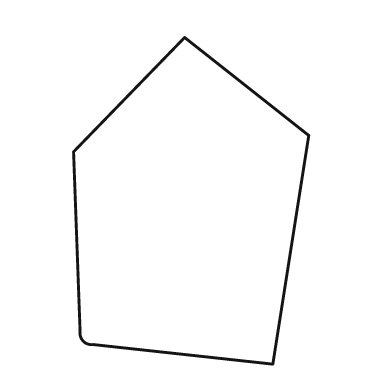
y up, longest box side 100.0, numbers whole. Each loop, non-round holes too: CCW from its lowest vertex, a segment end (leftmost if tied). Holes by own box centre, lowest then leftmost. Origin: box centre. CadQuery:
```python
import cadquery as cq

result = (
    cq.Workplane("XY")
    .moveTo(25.0, -50.0)
    .lineTo(36.0, 20.0)
    .lineTo(-2.0, 50.0)
    .lineTo(-36.0, 15.0)
    .lineTo(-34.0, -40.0)
    .threePointArc((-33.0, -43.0), (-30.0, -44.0))
    .close()
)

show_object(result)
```